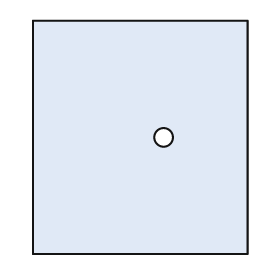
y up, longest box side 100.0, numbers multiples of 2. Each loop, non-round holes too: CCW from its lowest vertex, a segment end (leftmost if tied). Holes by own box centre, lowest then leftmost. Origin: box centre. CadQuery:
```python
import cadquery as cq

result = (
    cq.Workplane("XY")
    .moveTo(-46.0, -50.0)
    .lineTo(46.0, -50.0)
    .lineTo(46.0, 50.0)
    .lineTo(-46.0, 50.0)
    .close()
    .moveTo(10.0, 0.0)
    .circle(4.0)
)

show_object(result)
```